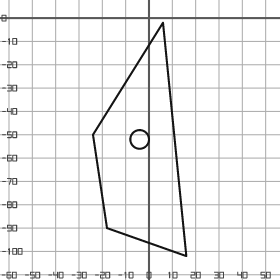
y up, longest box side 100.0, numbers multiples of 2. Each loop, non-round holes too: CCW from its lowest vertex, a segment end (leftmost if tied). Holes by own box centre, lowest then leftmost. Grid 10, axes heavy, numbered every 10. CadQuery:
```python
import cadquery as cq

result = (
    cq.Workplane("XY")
    .moveTo(16.0, -102.0)
    .lineTo(6.0, -2.0)
    .lineTo(-24.0, -50.0)
    .lineTo(-18.0, -90.0)
    .close()
    .moveTo(-4.0, -52.0)
    .circle(4.0)
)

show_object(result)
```